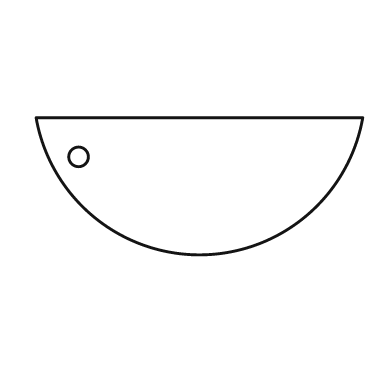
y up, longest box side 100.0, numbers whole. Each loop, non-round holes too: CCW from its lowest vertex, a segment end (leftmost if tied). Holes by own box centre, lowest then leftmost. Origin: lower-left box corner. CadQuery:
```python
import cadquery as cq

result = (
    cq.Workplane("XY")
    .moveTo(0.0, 42.0)
    .threePointArc((50.0, 0.0), (100.0, 42.0))
    .close()
    .moveTo(13.0, 30.0)
    .circle(3.0)
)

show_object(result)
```